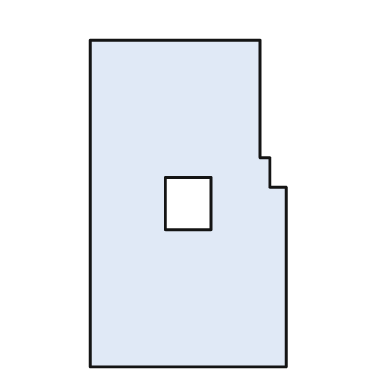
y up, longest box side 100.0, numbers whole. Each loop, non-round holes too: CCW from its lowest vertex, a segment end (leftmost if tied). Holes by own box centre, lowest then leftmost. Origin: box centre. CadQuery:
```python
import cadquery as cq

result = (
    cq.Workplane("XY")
    .moveTo(-30.0, -50.0)
    .lineTo(30.0, -50.0)
    .lineTo(30.0, 5.0)
    .lineTo(25.0, 5.0)
    .lineTo(25.0, 14.0)
    .lineTo(22.0, 14.0)
    .lineTo(22.0, 50.0)
    .lineTo(-30.0, 50.0)
    .close()
    .moveTo(-7.0, -8.0)
    .lineTo(7.0, -8.0)
    .lineTo(7.0, 8.0)
    .lineTo(-7.0, 8.0)
    .close()
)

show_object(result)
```